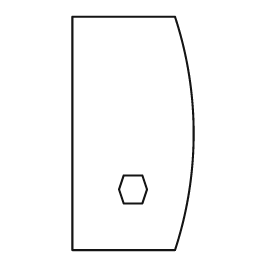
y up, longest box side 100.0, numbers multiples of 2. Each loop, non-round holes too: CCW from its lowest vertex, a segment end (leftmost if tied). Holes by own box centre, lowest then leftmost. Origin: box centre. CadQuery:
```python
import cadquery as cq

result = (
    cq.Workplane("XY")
    .moveTo(-26.0, -50.0)
    .lineTo(18.0, -50.0)
    .threePointArc((26.0, 0.0), (18.0, 50.0))
    .lineTo(-26.0, 50.0)
    .close()
    .moveTo(-4.0, -30.0)
    .lineTo(4.0, -30.0)
    .lineTo(6.0, -24.0)
    .lineTo(4.0, -18.0)
    .lineTo(-4.0, -18.0)
    .lineTo(-6.0, -24.0)
    .close()
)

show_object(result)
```